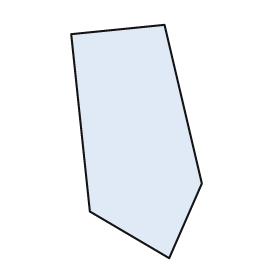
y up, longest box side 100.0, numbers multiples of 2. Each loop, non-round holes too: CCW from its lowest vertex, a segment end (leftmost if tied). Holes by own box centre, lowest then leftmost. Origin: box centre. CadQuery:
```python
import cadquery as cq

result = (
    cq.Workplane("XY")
    .moveTo(14.0, -50.0)
    .lineTo(28.0, -18.0)
    .lineTo(12.0, 50.0)
    .lineTo(-28.0, 46.0)
    .lineTo(-20.0, -30.0)
    .close()
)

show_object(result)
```